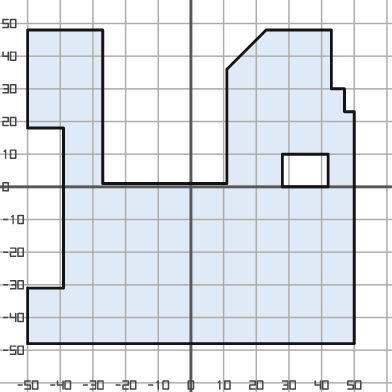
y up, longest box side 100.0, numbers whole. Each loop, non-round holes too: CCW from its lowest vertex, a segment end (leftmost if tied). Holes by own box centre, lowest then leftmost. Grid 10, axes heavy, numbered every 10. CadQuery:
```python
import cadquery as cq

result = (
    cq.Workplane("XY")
    .moveTo(-50.0, -48.0)
    .lineTo(50.0, -48.0)
    .lineTo(50.0, 23.0)
    .lineTo(47.0, 23.0)
    .lineTo(47.0, 30.0)
    .lineTo(43.0, 30.0)
    .lineTo(43.0, 48.0)
    .lineTo(23.0, 48.0)
    .lineTo(11.0, 36.0)
    .lineTo(11.0, 1.0)
    .lineTo(-27.0, 1.0)
    .lineTo(-27.0, 48.0)
    .lineTo(-50.0, 48.0)
    .lineTo(-50.0, 18.0)
    .lineTo(-39.0, 18.0)
    .lineTo(-39.0, -31.0)
    .lineTo(-50.0, -31.0)
    .close()
    .moveTo(28.0, 0.0)
    .lineTo(42.0, 0.0)
    .lineTo(42.0, 10.0)
    .lineTo(28.0, 10.0)
    .close()
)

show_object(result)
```